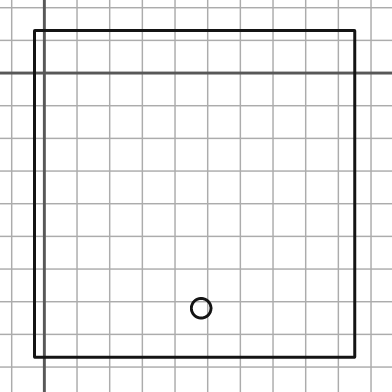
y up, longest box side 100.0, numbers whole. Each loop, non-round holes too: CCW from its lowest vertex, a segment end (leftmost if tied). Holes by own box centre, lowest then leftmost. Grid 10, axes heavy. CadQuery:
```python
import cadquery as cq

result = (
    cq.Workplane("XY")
    .moveTo(-3.0, -87.0)
    .lineTo(95.0, -87.0)
    .lineTo(95.0, 13.0)
    .lineTo(-3.0, 13.0)
    .close()
    .moveTo(48.0, -72.0)
    .circle(3.0)
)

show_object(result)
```